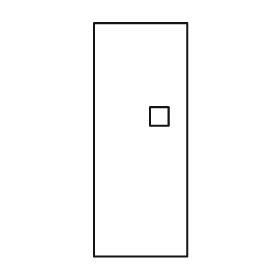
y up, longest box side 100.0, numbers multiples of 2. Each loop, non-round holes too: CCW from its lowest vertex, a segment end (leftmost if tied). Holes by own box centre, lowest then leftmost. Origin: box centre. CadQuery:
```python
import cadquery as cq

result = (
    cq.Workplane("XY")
    .moveTo(-20.0, -50.0)
    .lineTo(20.0, -50.0)
    .lineTo(20.0, 50.0)
    .lineTo(-20.0, 50.0)
    .close()
    .moveTo(4.0, 6.0)
    .lineTo(12.0, 6.0)
    .lineTo(12.0, 14.0)
    .lineTo(4.0, 14.0)
    .close()
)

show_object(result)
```